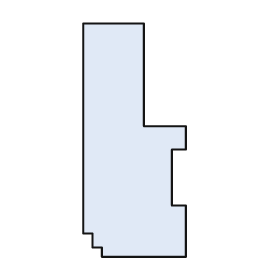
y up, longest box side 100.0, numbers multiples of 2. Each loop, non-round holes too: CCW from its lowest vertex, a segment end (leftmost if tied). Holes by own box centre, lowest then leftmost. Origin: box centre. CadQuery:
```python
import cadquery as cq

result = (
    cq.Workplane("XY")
    .moveTo(-14.0, -50.0)
    .lineTo(22.0, -50.0)
    .lineTo(22.0, -28.0)
    .lineTo(16.0, -28.0)
    .lineTo(16.0, -4.0)
    .lineTo(22.0, -4.0)
    .lineTo(22.0, 6.0)
    .lineTo(4.0, 6.0)
    .lineTo(4.0, 50.0)
    .lineTo(-22.0, 50.0)
    .lineTo(-22.0, -40.0)
    .lineTo(-18.0, -40.0)
    .lineTo(-18.0, -46.0)
    .lineTo(-14.0, -46.0)
    .close()
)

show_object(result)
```